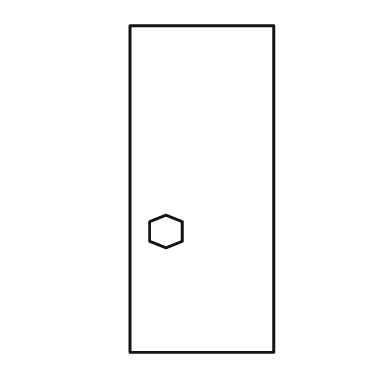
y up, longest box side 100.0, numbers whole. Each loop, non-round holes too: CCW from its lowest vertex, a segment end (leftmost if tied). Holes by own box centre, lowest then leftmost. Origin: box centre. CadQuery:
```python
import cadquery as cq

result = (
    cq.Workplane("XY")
    .moveTo(-22.0, -50.0)
    .lineTo(22.0, -50.0)
    .lineTo(22.0, 50.0)
    .lineTo(-22.0, 50.0)
    .close()
    .moveTo(-11.0, -18.0)
    .lineTo(-6.0, -16.0)
    .lineTo(-6.0, -10.0)
    .lineTo(-11.0, -8.0)
    .lineTo(-16.0, -10.0)
    .lineTo(-16.0, -16.0)
    .close()
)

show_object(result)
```